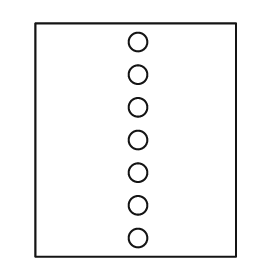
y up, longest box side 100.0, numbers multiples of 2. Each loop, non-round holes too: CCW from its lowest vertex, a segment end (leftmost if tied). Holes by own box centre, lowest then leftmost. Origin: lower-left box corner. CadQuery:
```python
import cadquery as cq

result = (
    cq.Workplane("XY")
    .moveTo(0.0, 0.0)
    .lineTo(86.0, 0.0)
    .lineTo(86.0, 100.0)
    .lineTo(0.0, 100.0)
    .close()
    .moveTo(44.0, 8.0)
    .circle(4.0)
    .moveTo(44.0, 22.0)
    .circle(4.0)
    .moveTo(44.0, 36.0)
    .circle(4.0)
    .moveTo(44.0, 50.0)
    .circle(4.0)
    .moveTo(44.0, 64.0)
    .circle(4.0)
    .moveTo(44.0, 78.0)
    .circle(4.0)
    .moveTo(44.0, 92.0)
    .circle(4.0)
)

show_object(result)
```